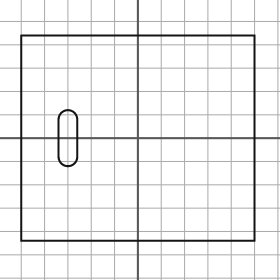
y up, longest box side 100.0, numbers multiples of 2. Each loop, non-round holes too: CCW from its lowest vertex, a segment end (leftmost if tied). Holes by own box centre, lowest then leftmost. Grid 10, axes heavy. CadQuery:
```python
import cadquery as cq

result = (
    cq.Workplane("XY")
    .moveTo(-50.0, -44.0)
    .lineTo(50.0, -44.0)
    .lineTo(50.0, 44.0)
    .lineTo(-50.0, 44.0)
    .close()
    .moveTo(-34.0, -8.0)
    .threePointArc((-30.0, -12.0), (-26.0, -8.0))
    .lineTo(-26.0, 8.0)
    .threePointArc((-30.0, 12.0), (-34.0, 8.0))
    .close()
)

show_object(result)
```